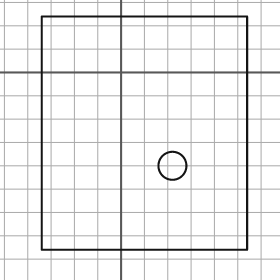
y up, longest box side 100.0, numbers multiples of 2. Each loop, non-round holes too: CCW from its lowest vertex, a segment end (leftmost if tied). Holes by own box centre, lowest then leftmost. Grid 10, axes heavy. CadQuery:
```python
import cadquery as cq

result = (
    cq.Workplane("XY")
    .moveTo(-34.0, -76.0)
    .lineTo(54.0, -76.0)
    .lineTo(54.0, 24.0)
    .lineTo(-34.0, 24.0)
    .close()
    .moveTo(22.0, -40.0)
    .circle(6.0)
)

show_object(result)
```